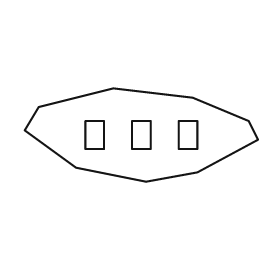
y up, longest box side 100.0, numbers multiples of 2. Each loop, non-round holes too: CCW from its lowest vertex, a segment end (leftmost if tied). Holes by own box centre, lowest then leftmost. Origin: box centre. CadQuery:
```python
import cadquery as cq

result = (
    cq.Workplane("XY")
    .moveTo(2.0, -20.0)
    .lineTo(24.0, -16.0)
    .lineTo(50.0, -2.0)
    .lineTo(46.0, 6.0)
    .lineTo(22.0, 16.0)
    .lineTo(-12.0, 20.0)
    .lineTo(-44.0, 12.0)
    .lineTo(-50.0, 2.0)
    .lineTo(-28.0, -14.0)
    .close()
    .moveTo(-24.0, -6.0)
    .lineTo(-16.0, -6.0)
    .lineTo(-16.0, 6.0)
    .lineTo(-24.0, 6.0)
    .close()
    .moveTo(-4.0, -6.0)
    .lineTo(4.0, -6.0)
    .lineTo(4.0, 6.0)
    .lineTo(-4.0, 6.0)
    .close()
    .moveTo(16.0, -6.0)
    .lineTo(24.0, -6.0)
    .lineTo(24.0, 6.0)
    .lineTo(16.0, 6.0)
    .close()
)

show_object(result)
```